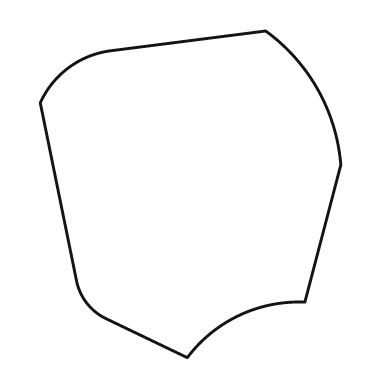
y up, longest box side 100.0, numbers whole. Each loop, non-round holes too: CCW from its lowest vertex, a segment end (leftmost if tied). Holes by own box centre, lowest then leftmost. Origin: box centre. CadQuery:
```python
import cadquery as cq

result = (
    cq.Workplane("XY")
    .moveTo(-1.0, -50.0)
    .threePointArc((15.0, -37.0), (35.0, -33.0))
    .lineTo(46.0, 9.0)
    .threePointArc((39.0, 32.0), (23.0, 50.0))
    .lineTo(-24.0, 44.0)
    .threePointArc((-37.0, 39.0), (-46.0, 28.0))
    .lineTo(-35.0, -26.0)
    .threePointArc((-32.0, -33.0), (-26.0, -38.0))
    .close()
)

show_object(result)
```